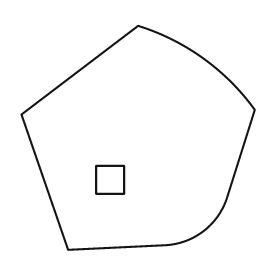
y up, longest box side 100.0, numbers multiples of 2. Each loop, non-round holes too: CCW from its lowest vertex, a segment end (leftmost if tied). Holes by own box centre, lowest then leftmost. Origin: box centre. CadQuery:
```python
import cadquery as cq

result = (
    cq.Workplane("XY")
    .moveTo(-30.0, -48.0)
    .lineTo(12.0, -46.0)
    .threePointArc((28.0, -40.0), (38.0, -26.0))
    .lineTo(50.0, 12.0)
    .threePointArc((28.0, 34.0), (0.0, 48.0))
    .lineTo(-50.0, 10.0)
    .close()
    .moveTo(-18.0, -24.0)
    .lineTo(-6.0, -24.0)
    .lineTo(-6.0, -12.0)
    .lineTo(-18.0, -12.0)
    .close()
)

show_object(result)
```